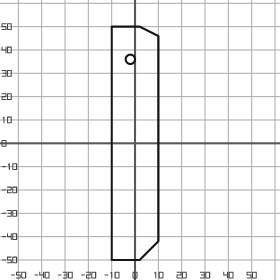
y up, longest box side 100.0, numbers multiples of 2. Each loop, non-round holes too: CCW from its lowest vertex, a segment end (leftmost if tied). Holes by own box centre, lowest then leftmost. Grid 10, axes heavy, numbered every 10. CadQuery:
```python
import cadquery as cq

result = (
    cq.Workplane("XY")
    .moveTo(-10.0, -50.0)
    .lineTo(2.0, -50.0)
    .lineTo(10.0, -42.0)
    .lineTo(10.0, 46.0)
    .lineTo(2.0, 50.0)
    .lineTo(-10.0, 50.0)
    .close()
    .moveTo(-2.0, 36.0)
    .circle(2.0)
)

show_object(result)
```